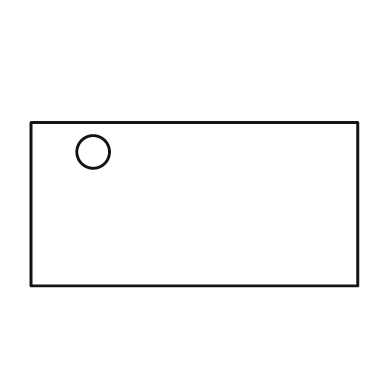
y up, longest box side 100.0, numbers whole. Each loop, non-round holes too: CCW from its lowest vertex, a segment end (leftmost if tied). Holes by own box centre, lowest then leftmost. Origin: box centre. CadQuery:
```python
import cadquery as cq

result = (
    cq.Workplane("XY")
    .moveTo(-50.0, -25.0)
    .lineTo(50.0, -25.0)
    .lineTo(50.0, 25.0)
    .lineTo(-50.0, 25.0)
    .close()
    .moveTo(-31.0, 16.0)
    .circle(5.0)
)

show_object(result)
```